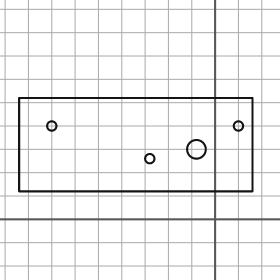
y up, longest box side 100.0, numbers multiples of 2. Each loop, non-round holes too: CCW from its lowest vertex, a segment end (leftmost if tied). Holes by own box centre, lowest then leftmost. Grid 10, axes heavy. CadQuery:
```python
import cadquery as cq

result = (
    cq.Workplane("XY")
    .moveTo(-84.0, 12.0)
    .lineTo(16.0, 12.0)
    .lineTo(16.0, 52.0)
    .lineTo(-84.0, 52.0)
    .close()
    .moveTo(-28.0, 26.0)
    .circle(2.0)
    .moveTo(-8.0, 30.0)
    .circle(4.0)
    .moveTo(-70.0, 40.0)
    .circle(2.0)
    .moveTo(10.0, 40.0)
    .circle(2.0)
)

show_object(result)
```